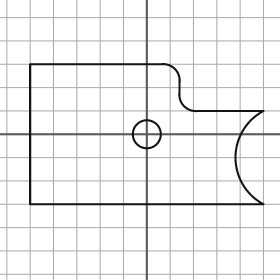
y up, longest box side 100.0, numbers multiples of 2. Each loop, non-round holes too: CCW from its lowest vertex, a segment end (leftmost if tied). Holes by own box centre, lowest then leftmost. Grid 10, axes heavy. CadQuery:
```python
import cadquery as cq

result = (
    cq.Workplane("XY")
    .moveTo(-50.0, -30.0)
    .lineTo(50.0, -30.0)
    .threePointArc((38.0, -10.0), (50.0, 10.0))
    .lineTo(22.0, 10.0)
    .threePointArc((16.0, 12.0), (14.0, 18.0))
    .lineTo(14.0, 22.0)
    .threePointArc((12.0, 28.0), (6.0, 30.0))
    .lineTo(-50.0, 30.0)
    .close()
    .moveTo(0.0, 0.0)
    .circle(6.0)
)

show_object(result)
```